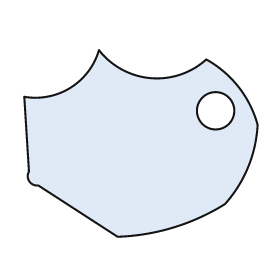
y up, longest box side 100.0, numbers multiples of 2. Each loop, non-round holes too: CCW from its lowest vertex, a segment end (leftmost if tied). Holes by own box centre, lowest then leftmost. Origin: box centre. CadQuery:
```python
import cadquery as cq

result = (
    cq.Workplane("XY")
    .moveTo(-10.0, -40.0)
    .threePointArc((14.0, -36.0), (36.0, -26.0))
    .threePointArc((46.0, -10.0), (50.0, 8.0))
    .threePointArc((42.0, 24.0), (28.0, 36.0))
    .threePointArc((4.0, 28.0), (-18.0, 40.0))
    .threePointArc((-30.0, 24.0), (-50.0, 20.0))
    .lineTo(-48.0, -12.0)
    .threePointArc((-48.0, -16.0), (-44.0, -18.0))
    .close()
    .moveTo(32.0, 14.0)
    .circle(8.0)
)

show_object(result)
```